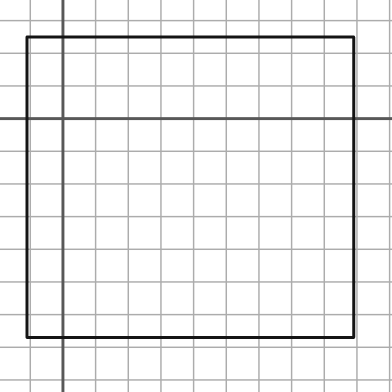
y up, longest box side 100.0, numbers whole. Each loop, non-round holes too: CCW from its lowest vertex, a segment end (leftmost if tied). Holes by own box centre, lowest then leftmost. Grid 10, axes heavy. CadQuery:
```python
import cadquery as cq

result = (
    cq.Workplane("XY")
    .moveTo(-11.0, -67.0)
    .lineTo(89.0, -67.0)
    .lineTo(89.0, 25.0)
    .lineTo(-11.0, 25.0)
    .close()
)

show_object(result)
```